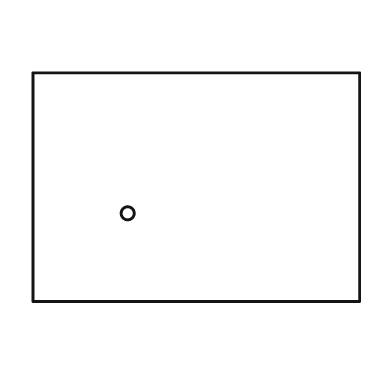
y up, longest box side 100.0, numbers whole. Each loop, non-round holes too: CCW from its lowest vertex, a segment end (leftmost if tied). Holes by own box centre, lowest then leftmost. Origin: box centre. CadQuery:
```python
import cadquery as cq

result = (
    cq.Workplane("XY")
    .moveTo(-50.0, -35.0)
    .lineTo(50.0, -35.0)
    .lineTo(50.0, 35.0)
    .lineTo(-50.0, 35.0)
    .close()
    .moveTo(-21.0, -8.0)
    .circle(2.0)
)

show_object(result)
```